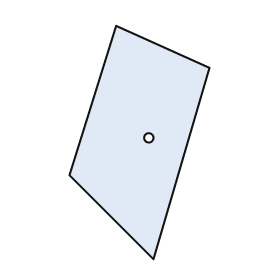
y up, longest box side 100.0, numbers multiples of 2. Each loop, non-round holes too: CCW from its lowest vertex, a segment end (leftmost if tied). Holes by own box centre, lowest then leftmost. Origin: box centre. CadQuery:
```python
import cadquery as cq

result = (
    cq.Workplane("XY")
    .moveTo(6.0, -50.0)
    .lineTo(30.0, 32.0)
    .lineTo(-10.0, 50.0)
    .lineTo(-30.0, -14.0)
    .close()
    .moveTo(4.0, 2.0)
    .circle(2.0)
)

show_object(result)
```